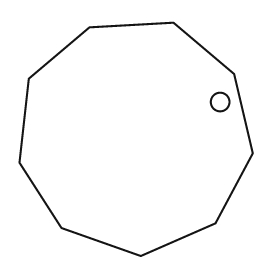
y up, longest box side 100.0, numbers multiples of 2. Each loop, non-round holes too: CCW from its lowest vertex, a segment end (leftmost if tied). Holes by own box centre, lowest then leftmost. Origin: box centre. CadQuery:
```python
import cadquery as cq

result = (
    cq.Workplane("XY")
    .moveTo(2.0, -50.0)
    .lineTo(34.0, -36.0)
    .lineTo(50.0, -6.0)
    .lineTo(42.0, 28.0)
    .lineTo(16.0, 50.0)
    .lineTo(-20.0, 48.0)
    .lineTo(-46.0, 26.0)
    .lineTo(-50.0, -10.0)
    .lineTo(-32.0, -38.0)
    .close()
    .moveTo(36.0, 16.0)
    .circle(4.0)
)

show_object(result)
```